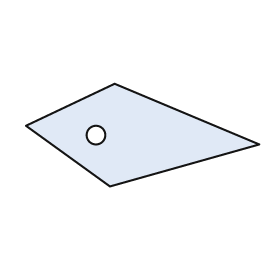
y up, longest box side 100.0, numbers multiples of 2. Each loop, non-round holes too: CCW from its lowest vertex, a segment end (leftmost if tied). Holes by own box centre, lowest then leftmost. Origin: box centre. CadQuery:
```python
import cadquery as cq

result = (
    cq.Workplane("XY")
    .moveTo(-14.0, -22.0)
    .lineTo(50.0, -4.0)
    .lineTo(-12.0, 22.0)
    .lineTo(-50.0, 4.0)
    .close()
    .moveTo(-20.0, 0.0)
    .circle(4.0)
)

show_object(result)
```